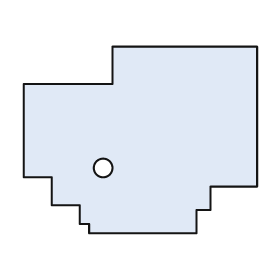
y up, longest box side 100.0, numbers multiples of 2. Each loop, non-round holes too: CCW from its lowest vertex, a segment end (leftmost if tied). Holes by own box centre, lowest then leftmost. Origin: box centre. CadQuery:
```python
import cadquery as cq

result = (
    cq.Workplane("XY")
    .moveTo(-22.0, -40.0)
    .lineTo(24.0, -40.0)
    .lineTo(24.0, -30.0)
    .lineTo(30.0, -30.0)
    .lineTo(30.0, -20.0)
    .lineTo(50.0, -20.0)
    .lineTo(50.0, 40.0)
    .lineTo(-12.0, 40.0)
    .lineTo(-12.0, 24.0)
    .lineTo(-50.0, 24.0)
    .lineTo(-50.0, -16.0)
    .lineTo(-38.0, -16.0)
    .lineTo(-38.0, -28.0)
    .lineTo(-26.0, -28.0)
    .lineTo(-26.0, -36.0)
    .lineTo(-22.0, -36.0)
    .close()
    .moveTo(-16.0, -12.0)
    .circle(4.0)
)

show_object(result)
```